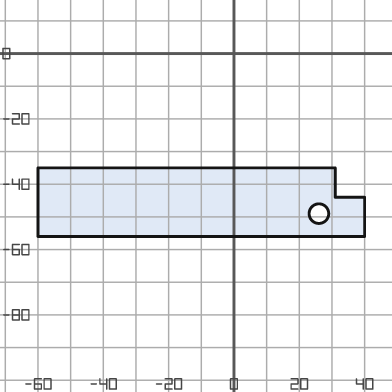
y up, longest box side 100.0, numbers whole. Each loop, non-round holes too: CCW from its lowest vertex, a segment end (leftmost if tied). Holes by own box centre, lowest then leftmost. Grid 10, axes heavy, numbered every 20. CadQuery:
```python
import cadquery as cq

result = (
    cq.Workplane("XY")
    .moveTo(-60.0, -56.0)
    .lineTo(40.0, -56.0)
    .lineTo(40.0, -44.0)
    .lineTo(31.0, -44.0)
    .lineTo(31.0, -35.0)
    .lineTo(-60.0, -35.0)
    .close()
    .moveTo(26.0, -49.0)
    .circle(3.0)
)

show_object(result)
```